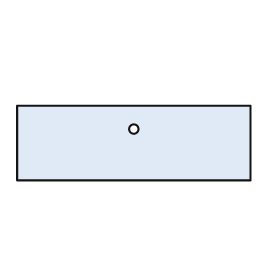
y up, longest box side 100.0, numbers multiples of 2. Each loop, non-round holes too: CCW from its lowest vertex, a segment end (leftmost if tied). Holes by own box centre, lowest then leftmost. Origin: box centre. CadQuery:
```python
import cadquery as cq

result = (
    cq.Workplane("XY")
    .moveTo(-50.0, -16.0)
    .lineTo(50.0, -16.0)
    .lineTo(50.0, 16.0)
    .lineTo(-50.0, 16.0)
    .close()
    .moveTo(0.0, 6.0)
    .circle(2.0)
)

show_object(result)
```